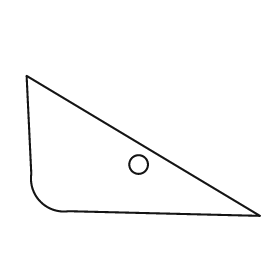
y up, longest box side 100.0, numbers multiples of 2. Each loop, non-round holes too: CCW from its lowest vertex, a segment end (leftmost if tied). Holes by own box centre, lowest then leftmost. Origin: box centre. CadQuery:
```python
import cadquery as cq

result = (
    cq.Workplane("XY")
    .moveTo(50.0, -30.0)
    .lineTo(-50.0, 30.0)
    .lineTo(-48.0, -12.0)
    .threePointArc((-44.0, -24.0), (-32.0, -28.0))
    .close()
    .moveTo(-2.0, -8.0)
    .circle(4.0)
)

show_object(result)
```